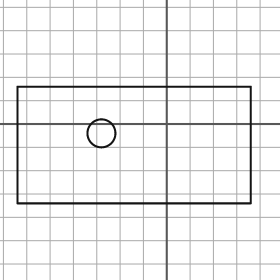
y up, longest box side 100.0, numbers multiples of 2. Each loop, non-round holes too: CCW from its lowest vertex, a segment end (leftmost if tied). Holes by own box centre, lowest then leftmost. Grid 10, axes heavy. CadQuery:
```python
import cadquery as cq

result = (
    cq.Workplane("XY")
    .moveTo(-64.0, -34.0)
    .lineTo(36.0, -34.0)
    .lineTo(36.0, 16.0)
    .lineTo(-64.0, 16.0)
    .close()
    .moveTo(-28.0, -4.0)
    .circle(6.0)
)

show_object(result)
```